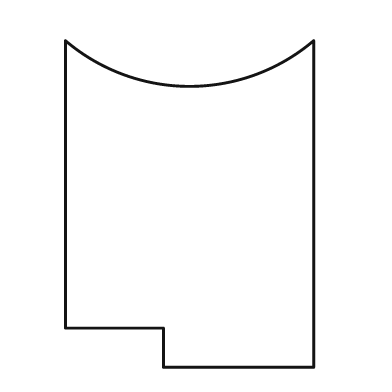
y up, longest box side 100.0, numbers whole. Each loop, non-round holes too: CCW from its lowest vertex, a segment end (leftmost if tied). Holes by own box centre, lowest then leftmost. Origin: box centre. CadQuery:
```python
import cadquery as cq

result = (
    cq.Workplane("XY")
    .moveTo(-8.0, -50.0)
    .lineTo(38.0, -50.0)
    .lineTo(38.0, 50.0)
    .threePointArc((0.0, 36.0), (-38.0, 50.0))
    .lineTo(-38.0, -38.0)
    .lineTo(-8.0, -38.0)
    .close()
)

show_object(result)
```